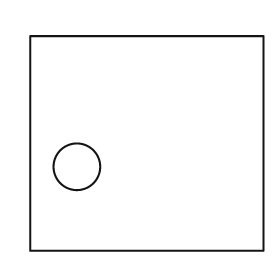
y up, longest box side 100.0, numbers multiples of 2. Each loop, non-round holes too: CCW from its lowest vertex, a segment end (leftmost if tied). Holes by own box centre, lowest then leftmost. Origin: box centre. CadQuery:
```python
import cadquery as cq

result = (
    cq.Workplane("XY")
    .moveTo(-50.0, -46.0)
    .lineTo(50.0, -46.0)
    .lineTo(50.0, 46.0)
    .lineTo(-50.0, 46.0)
    .close()
    .moveTo(-30.0, -10.0)
    .circle(10.0)
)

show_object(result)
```